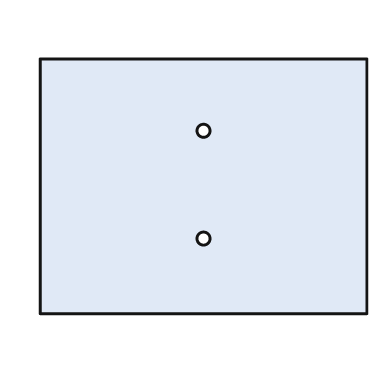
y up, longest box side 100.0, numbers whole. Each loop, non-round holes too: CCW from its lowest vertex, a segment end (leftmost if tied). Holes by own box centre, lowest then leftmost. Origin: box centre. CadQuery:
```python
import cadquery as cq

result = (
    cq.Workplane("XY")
    .moveTo(-50.0, -39.0)
    .lineTo(50.0, -39.0)
    .lineTo(50.0, 39.0)
    .lineTo(-50.0, 39.0)
    .close()
    .moveTo(0.0, -16.0)
    .circle(2.0)
    .moveTo(0.0, 17.0)
    .circle(2.0)
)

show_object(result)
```